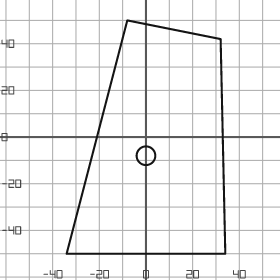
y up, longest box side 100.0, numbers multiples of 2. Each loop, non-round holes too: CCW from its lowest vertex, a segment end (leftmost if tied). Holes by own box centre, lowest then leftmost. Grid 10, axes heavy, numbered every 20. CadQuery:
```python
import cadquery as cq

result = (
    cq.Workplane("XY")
    .moveTo(-34.0, -50.0)
    .lineTo(34.0, -50.0)
    .lineTo(32.0, 42.0)
    .lineTo(-8.0, 50.0)
    .close()
    .moveTo(0.0, -8.0)
    .circle(4.0)
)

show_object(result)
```